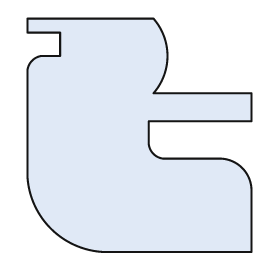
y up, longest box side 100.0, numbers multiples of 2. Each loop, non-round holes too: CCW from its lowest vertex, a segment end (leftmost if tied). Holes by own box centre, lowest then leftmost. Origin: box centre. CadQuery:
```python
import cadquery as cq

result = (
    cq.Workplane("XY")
    .moveTo(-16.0, -50.0)
    .lineTo(48.0, -50.0)
    .lineTo(48.0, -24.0)
    .threePointArc((44.0, -14.0), (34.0, -10.0))
    .lineTo(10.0, -10.0)
    .threePointArc((6.0, -8.0), (4.0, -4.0))
    .lineTo(4.0, 6.0)
    .lineTo(48.0, 6.0)
    .lineTo(48.0, 18.0)
    .lineTo(6.0, 18.0)
    .threePointArc((12.0, 34.0), (6.0, 50.0))
    .lineTo(-48.0, 50.0)
    .lineTo(-48.0, 44.0)
    .lineTo(-34.0, 44.0)
    .lineTo(-34.0, 34.0)
    .lineTo(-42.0, 34.0)
    .threePointArc((-46.0, 32.0), (-48.0, 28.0))
    .lineTo(-48.0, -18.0)
    .threePointArc((-38.0, -40.0), (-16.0, -50.0))
    .close()
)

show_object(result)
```